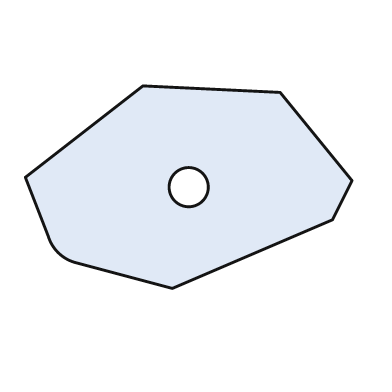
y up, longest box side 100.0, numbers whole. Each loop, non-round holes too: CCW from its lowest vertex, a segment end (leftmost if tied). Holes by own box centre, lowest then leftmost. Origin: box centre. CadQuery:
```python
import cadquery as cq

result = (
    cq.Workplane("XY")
    .moveTo(-5.0, -31.0)
    .lineTo(44.0, -10.0)
    .lineTo(50.0, 2.0)
    .lineTo(28.0, 29.0)
    .lineTo(-14.0, 31.0)
    .lineTo(-50.0, 3.0)
    .lineTo(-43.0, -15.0)
    .threePointArc((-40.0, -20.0), (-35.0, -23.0))
    .close()
    .moveTo(0.0, 0.0)
    .circle(6.0)
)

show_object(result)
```